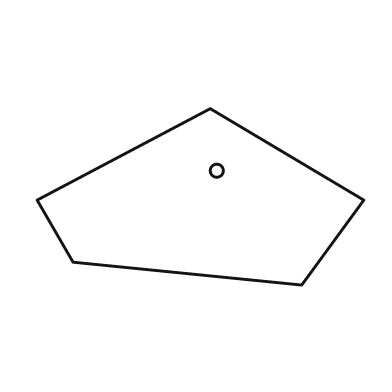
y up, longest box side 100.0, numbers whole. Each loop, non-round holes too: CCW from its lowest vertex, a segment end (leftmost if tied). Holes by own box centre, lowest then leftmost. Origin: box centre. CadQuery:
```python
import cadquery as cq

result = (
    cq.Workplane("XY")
    .moveTo(31.0, -27.0)
    .lineTo(50.0, -1.0)
    .lineTo(3.0, 27.0)
    .lineTo(-50.0, -1.0)
    .lineTo(-39.0, -20.0)
    .close()
    .moveTo(5.0, 8.0)
    .circle(2.0)
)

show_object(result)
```